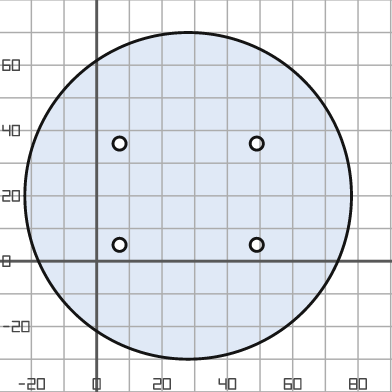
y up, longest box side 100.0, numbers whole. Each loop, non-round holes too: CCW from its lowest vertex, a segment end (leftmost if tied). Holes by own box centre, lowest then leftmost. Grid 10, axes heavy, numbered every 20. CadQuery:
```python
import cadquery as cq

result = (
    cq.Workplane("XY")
    .moveTo(28.0, 20.0)
    .circle(50.0)
    .moveTo(7.0, 5.0)
    .circle(2.0)
    .moveTo(49.0, 5.0)
    .circle(2.0)
    .moveTo(7.0, 36.0)
    .circle(2.0)
    .moveTo(49.0, 36.0)
    .circle(2.0)
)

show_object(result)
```